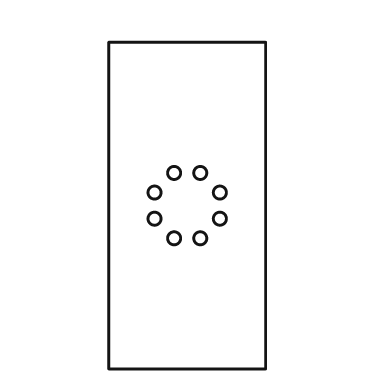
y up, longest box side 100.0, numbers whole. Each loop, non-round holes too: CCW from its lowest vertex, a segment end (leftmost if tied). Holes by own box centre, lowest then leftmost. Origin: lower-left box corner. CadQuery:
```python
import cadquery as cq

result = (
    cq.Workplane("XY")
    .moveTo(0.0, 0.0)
    .lineTo(48.0, 0.0)
    .lineTo(48.0, 100.0)
    .lineTo(0.0, 100.0)
    .close()
    .moveTo(20.0, 40.0)
    .circle(2.0)
    .moveTo(28.0, 40.0)
    .circle(2.0)
    .moveTo(14.0, 46.0)
    .circle(2.0)
    .moveTo(34.0, 46.0)
    .circle(2.0)
    .moveTo(14.0, 54.0)
    .circle(2.0)
    .moveTo(34.0, 54.0)
    .circle(2.0)
    .moveTo(20.0, 60.0)
    .circle(2.0)
    .moveTo(28.0, 60.0)
    .circle(2.0)
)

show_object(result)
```